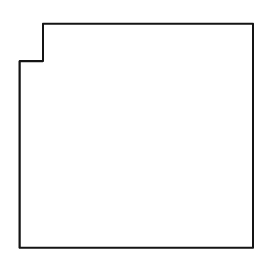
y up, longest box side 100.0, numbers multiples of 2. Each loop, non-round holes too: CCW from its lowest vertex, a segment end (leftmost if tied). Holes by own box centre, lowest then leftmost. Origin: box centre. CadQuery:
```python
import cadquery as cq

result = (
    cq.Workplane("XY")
    .moveTo(-50.0, -48.0)
    .lineTo(50.0, -48.0)
    .lineTo(50.0, 48.0)
    .lineTo(-40.0, 48.0)
    .lineTo(-40.0, 32.0)
    .lineTo(-50.0, 32.0)
    .close()
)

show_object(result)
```